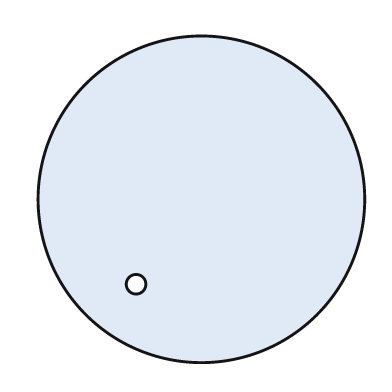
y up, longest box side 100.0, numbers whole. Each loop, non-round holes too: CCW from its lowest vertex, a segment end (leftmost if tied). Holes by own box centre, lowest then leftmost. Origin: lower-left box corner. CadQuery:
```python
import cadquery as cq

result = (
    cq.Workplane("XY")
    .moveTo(50.0, 50.0)
    .circle(50.0)
    .moveTo(30.0, 24.0)
    .circle(3.0)
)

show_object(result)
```